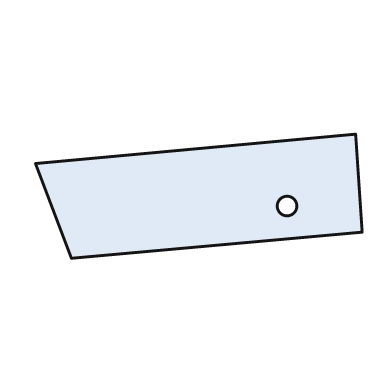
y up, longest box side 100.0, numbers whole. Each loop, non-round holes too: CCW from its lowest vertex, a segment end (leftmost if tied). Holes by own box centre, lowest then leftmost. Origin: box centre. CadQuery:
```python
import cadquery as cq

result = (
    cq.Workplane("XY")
    .moveTo(-39.0, -19.0)
    .lineTo(50.0, -11.0)
    .lineTo(48.0, 19.0)
    .lineTo(-50.0, 10.0)
    .close()
    .moveTo(27.0, -3.0)
    .circle(3.0)
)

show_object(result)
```